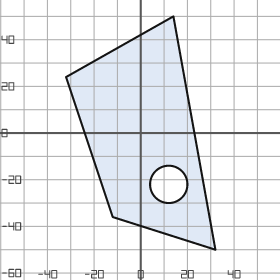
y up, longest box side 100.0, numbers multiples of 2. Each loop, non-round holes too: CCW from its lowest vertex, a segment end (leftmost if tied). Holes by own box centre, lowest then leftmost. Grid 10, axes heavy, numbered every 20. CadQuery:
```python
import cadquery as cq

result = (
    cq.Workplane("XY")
    .moveTo(32.0, -50.0)
    .lineTo(14.0, 50.0)
    .lineTo(-32.0, 24.0)
    .lineTo(-12.0, -36.0)
    .close()
    .moveTo(12.0, -22.0)
    .circle(8.0)
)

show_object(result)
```